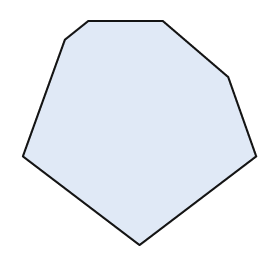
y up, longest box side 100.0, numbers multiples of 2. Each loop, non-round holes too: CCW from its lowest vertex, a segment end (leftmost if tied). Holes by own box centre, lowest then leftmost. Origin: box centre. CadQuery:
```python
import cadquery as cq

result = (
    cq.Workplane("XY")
    .moveTo(0.0, -48.0)
    .lineTo(50.0, -10.0)
    .lineTo(38.0, 24.0)
    .lineTo(10.0, 48.0)
    .lineTo(-22.0, 48.0)
    .lineTo(-32.0, 40.0)
    .lineTo(-50.0, -10.0)
    .close()
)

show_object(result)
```